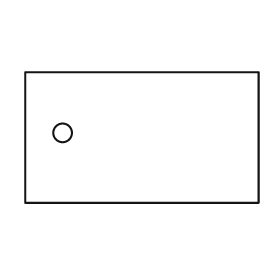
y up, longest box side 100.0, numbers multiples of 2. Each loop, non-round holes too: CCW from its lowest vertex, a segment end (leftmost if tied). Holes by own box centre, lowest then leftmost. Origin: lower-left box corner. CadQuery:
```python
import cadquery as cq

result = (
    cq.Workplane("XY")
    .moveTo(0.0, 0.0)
    .lineTo(100.0, 0.0)
    .lineTo(100.0, 56.0)
    .lineTo(0.0, 56.0)
    .close()
    .moveTo(16.0, 30.0)
    .circle(4.0)
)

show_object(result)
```